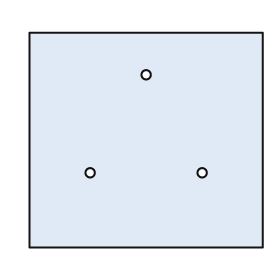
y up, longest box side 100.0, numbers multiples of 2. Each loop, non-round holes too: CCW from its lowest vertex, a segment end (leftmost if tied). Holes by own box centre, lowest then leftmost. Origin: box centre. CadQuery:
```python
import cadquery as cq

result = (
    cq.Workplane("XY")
    .moveTo(-50.0, -46.0)
    .lineTo(50.0, -46.0)
    .lineTo(50.0, 46.0)
    .lineTo(-50.0, 46.0)
    .close()
    .moveTo(-24.0, -14.0)
    .circle(2.0)
    .moveTo(24.0, -14.0)
    .circle(2.0)
    .moveTo(0.0, 28.0)
    .circle(2.0)
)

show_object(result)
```